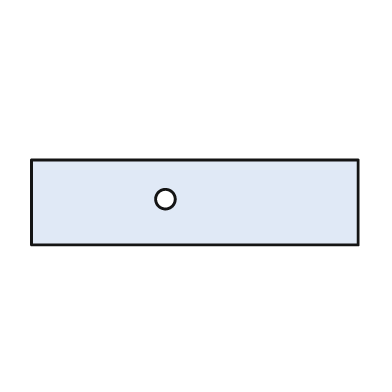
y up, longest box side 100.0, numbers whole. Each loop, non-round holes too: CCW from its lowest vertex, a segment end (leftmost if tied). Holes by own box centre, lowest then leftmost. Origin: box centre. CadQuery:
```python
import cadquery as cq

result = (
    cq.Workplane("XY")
    .moveTo(-50.0, -13.0)
    .lineTo(50.0, -13.0)
    .lineTo(50.0, 13.0)
    .lineTo(-50.0, 13.0)
    .close()
    .moveTo(-9.0, 1.0)
    .circle(3.0)
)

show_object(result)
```